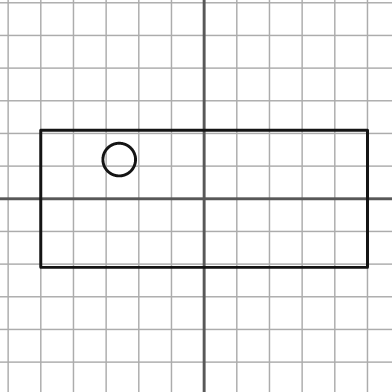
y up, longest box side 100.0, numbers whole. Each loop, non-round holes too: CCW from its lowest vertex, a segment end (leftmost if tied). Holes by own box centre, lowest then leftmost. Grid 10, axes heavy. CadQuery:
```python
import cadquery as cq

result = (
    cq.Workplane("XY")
    .moveTo(-50.0, -21.0)
    .lineTo(50.0, -21.0)
    .lineTo(50.0, 21.0)
    .lineTo(-50.0, 21.0)
    .close()
    .moveTo(-26.0, 12.0)
    .circle(5.0)
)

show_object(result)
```